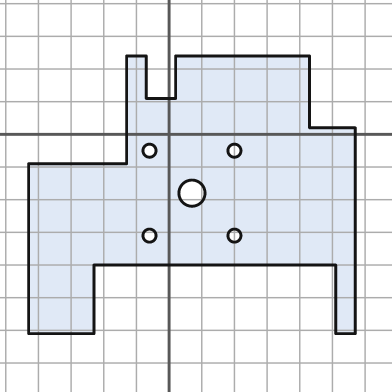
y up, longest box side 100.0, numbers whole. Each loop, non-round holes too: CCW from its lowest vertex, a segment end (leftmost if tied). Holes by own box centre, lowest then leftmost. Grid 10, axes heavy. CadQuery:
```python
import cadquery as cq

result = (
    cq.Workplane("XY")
    .moveTo(-43.0, -61.0)
    .lineTo(-23.0, -61.0)
    .lineTo(-23.0, -40.0)
    .lineTo(51.0, -40.0)
    .lineTo(51.0, -61.0)
    .lineTo(57.0, -61.0)
    .lineTo(57.0, 2.0)
    .lineTo(43.0, 2.0)
    .lineTo(43.0, 24.0)
    .lineTo(2.0, 24.0)
    .lineTo(2.0, 11.0)
    .lineTo(-7.0, 11.0)
    .lineTo(-7.0, 24.0)
    .lineTo(-13.0, 24.0)
    .lineTo(-13.0, -9.0)
    .lineTo(-43.0, -9.0)
    .close()
    .moveTo(-6.0, -31.0)
    .circle(2.0)
    .moveTo(20.0, -31.0)
    .circle(2.0)
    .moveTo(7.0, -18.0)
    .circle(4.0)
    .moveTo(-6.0, -5.0)
    .circle(2.0)
    .moveTo(20.0, -5.0)
    .circle(2.0)
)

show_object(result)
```